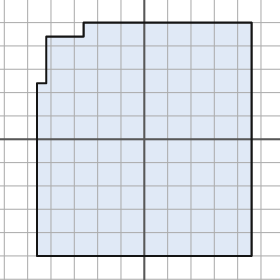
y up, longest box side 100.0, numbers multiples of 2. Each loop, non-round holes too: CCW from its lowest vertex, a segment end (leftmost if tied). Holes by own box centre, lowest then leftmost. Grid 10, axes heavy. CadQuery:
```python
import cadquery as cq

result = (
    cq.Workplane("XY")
    .moveTo(-46.0, -50.0)
    .lineTo(46.0, -50.0)
    .lineTo(46.0, 50.0)
    .lineTo(-26.0, 50.0)
    .lineTo(-26.0, 44.0)
    .lineTo(-42.0, 44.0)
    .lineTo(-42.0, 24.0)
    .lineTo(-46.0, 24.0)
    .close()
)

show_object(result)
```